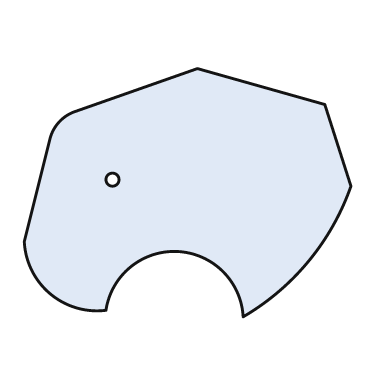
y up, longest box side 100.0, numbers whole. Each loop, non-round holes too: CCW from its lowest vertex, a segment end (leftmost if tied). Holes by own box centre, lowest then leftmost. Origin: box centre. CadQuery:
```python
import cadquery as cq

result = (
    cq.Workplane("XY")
    .moveTo(17.0, -38.0)
    .threePointArc((37.0, -21.0), (50.0, 2.0))
    .lineTo(42.0, 27.0)
    .lineTo(3.0, 38.0)
    .lineTo(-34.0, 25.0)
    .threePointArc((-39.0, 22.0), (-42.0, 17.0))
    .lineTo(-50.0, -15.0)
    .threePointArc((-42.0, -31.0), (-25.0, -36.0))
    .threePointArc((-3.0, -18.0), (17.0, -38.0))
    .close()
    .moveTo(-23.0, 4.0)
    .circle(2.0)
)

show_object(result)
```